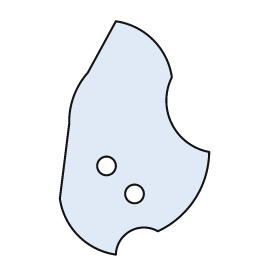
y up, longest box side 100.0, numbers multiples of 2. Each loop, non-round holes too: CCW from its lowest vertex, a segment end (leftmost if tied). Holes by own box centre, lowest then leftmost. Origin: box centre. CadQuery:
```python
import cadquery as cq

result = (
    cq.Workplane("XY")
    .moveTo(-8.0, -50.0)
    .threePointArc((-2.0, -40.0), (10.0, -40.0))
    .threePointArc((26.0, -26.0), (32.0, -6.0))
    .threePointArc((16.0, 6.0), (16.0, 26.0))
    .threePointArc((8.0, 42.0), (-8.0, 50.0))
    .lineTo(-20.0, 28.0)
    .threePointArc((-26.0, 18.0), (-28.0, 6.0))
    .lineTo(-32.0, -26.0)
    .threePointArc((-24.0, -42.0), (-8.0, -50.0))
    .close()
    .moveTo(0.0, -24.0)
    .circle(4.0)
    .moveTo(-12.0, -12.0)
    .circle(4.0)
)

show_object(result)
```